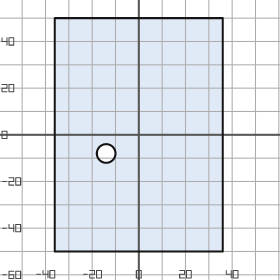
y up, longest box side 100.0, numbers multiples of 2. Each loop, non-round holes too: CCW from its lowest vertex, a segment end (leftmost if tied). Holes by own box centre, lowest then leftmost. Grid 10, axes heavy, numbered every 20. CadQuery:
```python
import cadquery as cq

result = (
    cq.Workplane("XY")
    .moveTo(-36.0, -50.0)
    .lineTo(36.0, -50.0)
    .lineTo(36.0, 50.0)
    .lineTo(-36.0, 50.0)
    .close()
    .moveTo(-14.0, -8.0)
    .circle(4.0)
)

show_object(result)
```